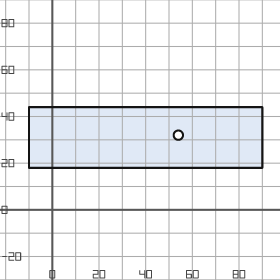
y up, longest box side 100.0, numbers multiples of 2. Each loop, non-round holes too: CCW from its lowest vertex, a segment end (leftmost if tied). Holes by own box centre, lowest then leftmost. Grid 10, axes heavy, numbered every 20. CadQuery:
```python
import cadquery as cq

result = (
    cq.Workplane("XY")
    .moveTo(-10.0, 18.0)
    .lineTo(90.0, 18.0)
    .lineTo(90.0, 44.0)
    .lineTo(-10.0, 44.0)
    .close()
    .moveTo(54.0, 32.0)
    .circle(2.0)
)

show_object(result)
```